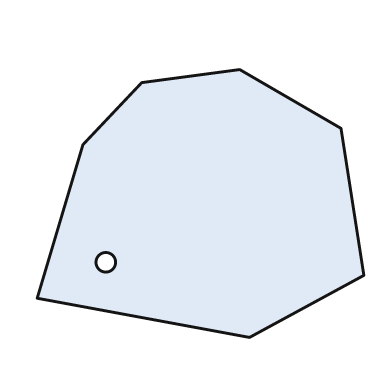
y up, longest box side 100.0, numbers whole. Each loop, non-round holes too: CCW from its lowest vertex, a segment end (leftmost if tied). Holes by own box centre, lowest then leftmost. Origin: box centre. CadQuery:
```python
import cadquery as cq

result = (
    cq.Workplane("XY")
    .moveTo(15.0, -41.0)
    .lineTo(50.0, -22.0)
    .lineTo(43.0, 23.0)
    .lineTo(12.0, 41.0)
    .lineTo(-18.0, 37.0)
    .lineTo(-36.0, 18.0)
    .lineTo(-50.0, -29.0)
    .close()
    .moveTo(-29.0, -18.0)
    .circle(3.0)
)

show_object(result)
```